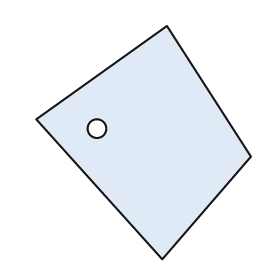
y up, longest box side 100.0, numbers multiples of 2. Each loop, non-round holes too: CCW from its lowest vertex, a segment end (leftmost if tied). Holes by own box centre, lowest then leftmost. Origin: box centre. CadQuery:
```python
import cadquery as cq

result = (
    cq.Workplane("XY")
    .moveTo(8.0, -50.0)
    .lineTo(46.0, -6.0)
    .lineTo(10.0, 50.0)
    .lineTo(-46.0, 10.0)
    .close()
    .moveTo(-20.0, 6.0)
    .circle(4.0)
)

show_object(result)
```